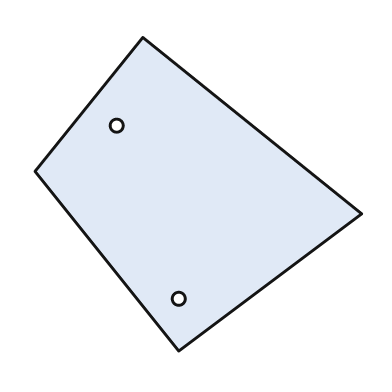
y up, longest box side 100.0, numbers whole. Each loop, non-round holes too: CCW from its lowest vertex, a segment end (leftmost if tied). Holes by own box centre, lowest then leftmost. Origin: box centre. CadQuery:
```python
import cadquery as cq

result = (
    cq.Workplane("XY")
    .moveTo(-6.0, -48.0)
    .lineTo(50.0, -6.0)
    .lineTo(-17.0, 48.0)
    .lineTo(-50.0, 7.0)
    .close()
    .moveTo(-6.0, -32.0)
    .circle(2.0)
    .moveTo(-25.0, 21.0)
    .circle(2.0)
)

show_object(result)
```